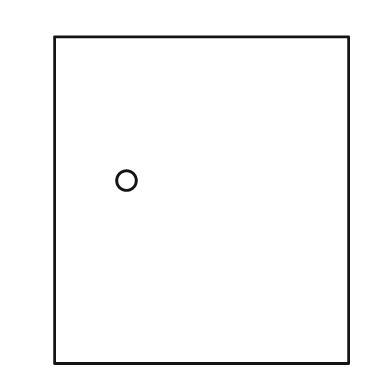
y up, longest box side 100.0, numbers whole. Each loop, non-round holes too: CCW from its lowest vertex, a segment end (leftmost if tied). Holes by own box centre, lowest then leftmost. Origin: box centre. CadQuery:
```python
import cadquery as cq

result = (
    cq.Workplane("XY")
    .moveTo(-45.0, -50.0)
    .lineTo(45.0, -50.0)
    .lineTo(45.0, 50.0)
    .lineTo(-45.0, 50.0)
    .close()
    .moveTo(-23.0, 6.0)
    .circle(3.0)
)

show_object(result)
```